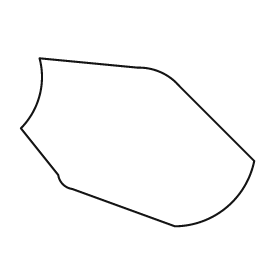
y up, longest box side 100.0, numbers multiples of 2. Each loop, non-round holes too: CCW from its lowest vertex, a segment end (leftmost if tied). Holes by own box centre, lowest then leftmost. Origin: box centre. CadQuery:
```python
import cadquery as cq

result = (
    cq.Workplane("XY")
    .moveTo(16.0, -36.0)
    .threePointArc((38.0, -28.0), (50.0, -8.0))
    .lineTo(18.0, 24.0)
    .threePointArc((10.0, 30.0), (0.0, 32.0))
    .lineTo(-42.0, 36.0)
    .threePointArc((-42.0, 20.0), (-50.0, 6.0))
    .lineTo(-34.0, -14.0)
    .threePointArc((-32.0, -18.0), (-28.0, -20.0))
    .close()
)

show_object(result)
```